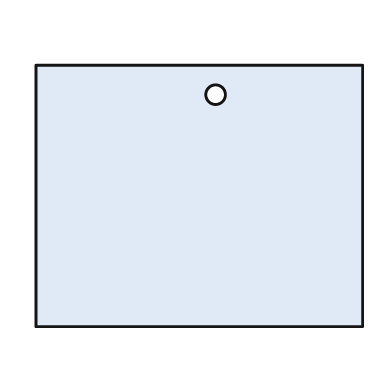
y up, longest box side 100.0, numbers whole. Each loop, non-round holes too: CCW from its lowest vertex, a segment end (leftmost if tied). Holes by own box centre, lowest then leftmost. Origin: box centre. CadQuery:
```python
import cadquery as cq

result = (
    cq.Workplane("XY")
    .moveTo(-50.0, -40.0)
    .lineTo(50.0, -40.0)
    .lineTo(50.0, 40.0)
    .lineTo(-50.0, 40.0)
    .close()
    .moveTo(5.0, 31.0)
    .circle(3.0)
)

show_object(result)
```